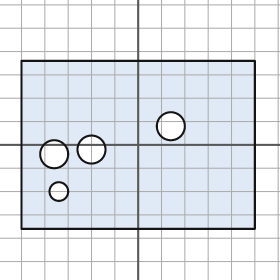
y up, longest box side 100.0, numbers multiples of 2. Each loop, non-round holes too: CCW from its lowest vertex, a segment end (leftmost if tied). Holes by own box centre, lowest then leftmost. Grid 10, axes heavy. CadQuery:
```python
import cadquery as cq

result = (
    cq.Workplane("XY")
    .moveTo(-50.0, -36.0)
    .lineTo(50.0, -36.0)
    .lineTo(50.0, 36.0)
    .lineTo(-50.0, 36.0)
    .close()
    .moveTo(-34.0, -20.0)
    .circle(4.0)
    .moveTo(-36.0, -4.0)
    .circle(6.0)
    .moveTo(-20.0, -2.0)
    .circle(6.0)
    .moveTo(14.0, 8.0)
    .circle(6.0)
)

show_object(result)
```